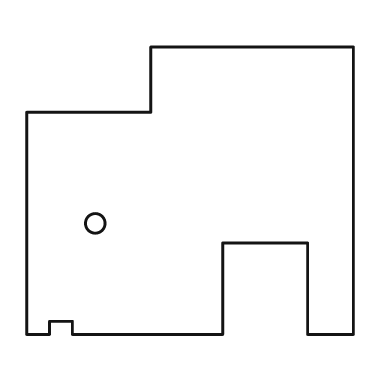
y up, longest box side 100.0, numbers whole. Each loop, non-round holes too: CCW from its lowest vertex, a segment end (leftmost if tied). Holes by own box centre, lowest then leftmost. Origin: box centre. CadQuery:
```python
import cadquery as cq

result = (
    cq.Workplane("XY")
    .moveTo(-50.0, -44.0)
    .lineTo(-43.0, -44.0)
    .lineTo(-43.0, -40.0)
    .lineTo(-36.0, -40.0)
    .lineTo(-36.0, -44.0)
    .lineTo(10.0, -44.0)
    .lineTo(10.0, -16.0)
    .lineTo(36.0, -16.0)
    .lineTo(36.0, -44.0)
    .lineTo(50.0, -44.0)
    .lineTo(50.0, 44.0)
    .lineTo(-12.0, 44.0)
    .lineTo(-12.0, 24.0)
    .lineTo(-50.0, 24.0)
    .close()
    .moveTo(-29.0, -10.0)
    .circle(3.0)
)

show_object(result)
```